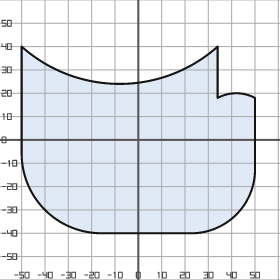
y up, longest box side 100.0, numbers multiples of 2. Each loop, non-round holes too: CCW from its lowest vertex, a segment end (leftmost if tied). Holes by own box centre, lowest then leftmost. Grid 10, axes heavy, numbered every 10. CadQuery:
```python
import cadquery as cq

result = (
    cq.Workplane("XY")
    .moveTo(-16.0, -40.0)
    .lineTo(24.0, -40.0)
    .threePointArc((42.0, -32.0), (50.0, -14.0))
    .lineTo(50.0, 18.0)
    .threePointArc((42.0, 20.0), (34.0, 18.0))
    .lineTo(34.0, 40.0)
    .threePointArc((-8.0, 24.0), (-50.0, 40.0))
    .lineTo(-50.0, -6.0)
    .threePointArc((-40.0, -30.0), (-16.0, -40.0))
    .close()
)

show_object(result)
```